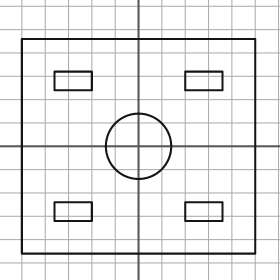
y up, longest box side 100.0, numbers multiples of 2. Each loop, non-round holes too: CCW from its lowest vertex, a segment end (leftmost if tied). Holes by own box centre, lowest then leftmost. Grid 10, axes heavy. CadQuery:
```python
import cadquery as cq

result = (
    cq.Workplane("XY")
    .moveTo(-50.0, -46.0)
    .lineTo(50.0, -46.0)
    .lineTo(50.0, 46.0)
    .lineTo(-50.0, 46.0)
    .close()
    .moveTo(-36.0, -32.0)
    .lineTo(-20.0, -32.0)
    .lineTo(-20.0, -24.0)
    .lineTo(-36.0, -24.0)
    .close()
    .moveTo(20.0, -32.0)
    .lineTo(36.0, -32.0)
    .lineTo(36.0, -24.0)
    .lineTo(20.0, -24.0)
    .close()
    .moveTo(0.0, 0.0)
    .circle(14.0)
    .moveTo(-36.0, 24.0)
    .lineTo(-20.0, 24.0)
    .lineTo(-20.0, 32.0)
    .lineTo(-36.0, 32.0)
    .close()
    .moveTo(20.0, 24.0)
    .lineTo(36.0, 24.0)
    .lineTo(36.0, 32.0)
    .lineTo(20.0, 32.0)
    .close()
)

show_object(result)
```